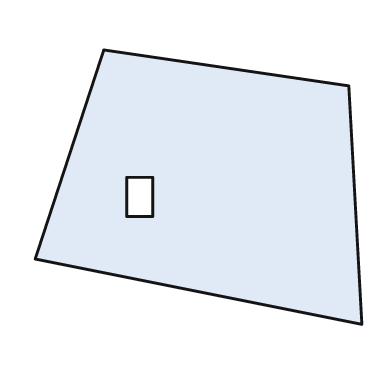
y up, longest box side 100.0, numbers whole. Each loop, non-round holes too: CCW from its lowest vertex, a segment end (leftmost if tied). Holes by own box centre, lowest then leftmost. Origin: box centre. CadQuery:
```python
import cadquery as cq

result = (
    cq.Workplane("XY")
    .moveTo(50.0, -42.0)
    .lineTo(46.0, 31.0)
    .lineTo(-29.0, 42.0)
    .lineTo(-50.0, -22.0)
    .close()
    .moveTo(-22.0, -9.0)
    .lineTo(-14.0, -9.0)
    .lineTo(-14.0, 3.0)
    .lineTo(-22.0, 3.0)
    .close()
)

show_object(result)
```